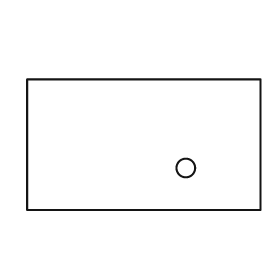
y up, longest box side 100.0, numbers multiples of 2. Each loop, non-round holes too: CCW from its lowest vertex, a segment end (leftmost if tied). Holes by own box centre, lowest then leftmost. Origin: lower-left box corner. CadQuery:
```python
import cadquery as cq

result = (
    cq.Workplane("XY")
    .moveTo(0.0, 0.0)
    .lineTo(100.0, 0.0)
    .lineTo(100.0, 56.0)
    .lineTo(0.0, 56.0)
    .close()
    .moveTo(68.0, 18.0)
    .circle(4.0)
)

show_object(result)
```